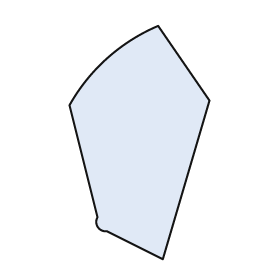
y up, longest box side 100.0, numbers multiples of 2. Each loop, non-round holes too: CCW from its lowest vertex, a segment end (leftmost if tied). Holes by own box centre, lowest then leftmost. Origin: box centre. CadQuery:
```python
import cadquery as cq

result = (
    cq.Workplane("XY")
    .moveTo(10.0, -50.0)
    .lineTo(30.0, 18.0)
    .lineTo(8.0, 50.0)
    .threePointArc((-14.0, 36.0), (-30.0, 16.0))
    .lineTo(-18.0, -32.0)
    .threePointArc((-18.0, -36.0), (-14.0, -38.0))
    .close()
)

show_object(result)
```